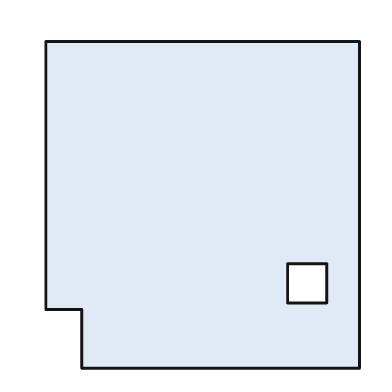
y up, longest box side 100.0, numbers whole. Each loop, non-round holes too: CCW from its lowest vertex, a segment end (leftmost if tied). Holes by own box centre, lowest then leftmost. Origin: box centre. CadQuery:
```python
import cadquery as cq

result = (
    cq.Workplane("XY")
    .moveTo(-37.0, -50.0)
    .lineTo(48.0, -50.0)
    .lineTo(48.0, 50.0)
    .lineTo(-48.0, 50.0)
    .lineTo(-48.0, -32.0)
    .lineTo(-37.0, -32.0)
    .close()
    .moveTo(26.0, -30.0)
    .lineTo(38.0, -30.0)
    .lineTo(38.0, -18.0)
    .lineTo(26.0, -18.0)
    .close()
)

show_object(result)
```